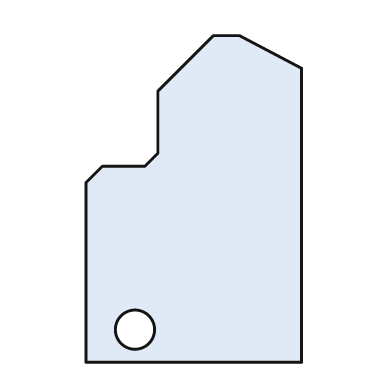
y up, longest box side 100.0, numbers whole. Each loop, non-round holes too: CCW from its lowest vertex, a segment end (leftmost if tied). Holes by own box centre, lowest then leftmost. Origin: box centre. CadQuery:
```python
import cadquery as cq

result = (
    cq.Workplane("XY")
    .moveTo(-33.0, -50.0)
    .lineTo(33.0, -50.0)
    .lineTo(33.0, 40.0)
    .lineTo(14.0, 50.0)
    .lineTo(6.0, 50.0)
    .lineTo(-11.0, 33.0)
    .lineTo(-11.0, 14.0)
    .lineTo(-15.0, 10.0)
    .lineTo(-28.0, 10.0)
    .lineTo(-33.0, 5.0)
    .close()
    .moveTo(-18.0, -40.0)
    .circle(6.0)
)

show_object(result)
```